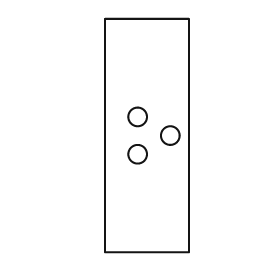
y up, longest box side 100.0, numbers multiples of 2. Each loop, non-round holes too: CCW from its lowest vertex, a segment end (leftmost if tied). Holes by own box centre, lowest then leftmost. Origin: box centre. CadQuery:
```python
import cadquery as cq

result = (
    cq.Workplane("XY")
    .moveTo(-18.0, -50.0)
    .lineTo(18.0, -50.0)
    .lineTo(18.0, 50.0)
    .lineTo(-18.0, 50.0)
    .close()
    .moveTo(-4.0, -8.0)
    .circle(4.0)
    .moveTo(10.0, 0.0)
    .circle(4.0)
    .moveTo(-4.0, 8.0)
    .circle(4.0)
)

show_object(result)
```